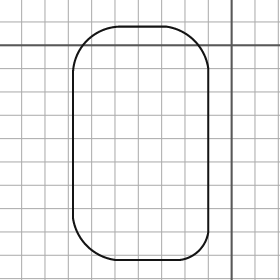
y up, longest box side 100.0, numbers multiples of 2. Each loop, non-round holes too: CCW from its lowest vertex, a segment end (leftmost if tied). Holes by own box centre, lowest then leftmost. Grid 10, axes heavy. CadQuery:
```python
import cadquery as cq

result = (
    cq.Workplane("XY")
    .moveTo(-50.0, -92.0)
    .lineTo(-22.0, -92.0)
    .threePointArc((-14.0, -88.0), (-10.0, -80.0))
    .lineTo(-10.0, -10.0)
    .threePointArc((-16.0, 2.0), (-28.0, 8.0))
    .lineTo(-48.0, 8.0)
    .threePointArc((-62.0, 2.0), (-68.0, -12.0))
    .lineTo(-68.0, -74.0)
    .threePointArc((-62.0, -86.0), (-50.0, -92.0))
    .close()
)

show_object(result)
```